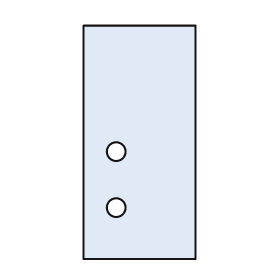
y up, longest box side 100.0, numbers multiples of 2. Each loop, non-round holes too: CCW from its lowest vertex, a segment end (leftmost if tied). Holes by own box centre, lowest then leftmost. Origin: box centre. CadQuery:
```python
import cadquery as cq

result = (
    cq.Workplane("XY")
    .moveTo(-24.0, -50.0)
    .lineTo(24.0, -50.0)
    .lineTo(24.0, 50.0)
    .lineTo(-24.0, 50.0)
    .close()
    .moveTo(-10.0, -28.0)
    .circle(4.0)
    .moveTo(-10.0, -4.0)
    .circle(4.0)
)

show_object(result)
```